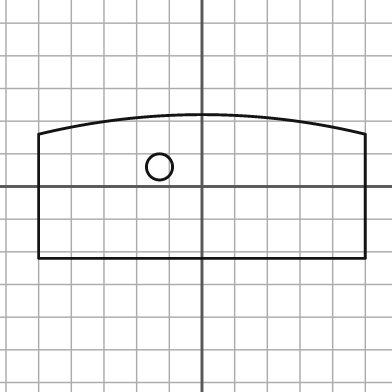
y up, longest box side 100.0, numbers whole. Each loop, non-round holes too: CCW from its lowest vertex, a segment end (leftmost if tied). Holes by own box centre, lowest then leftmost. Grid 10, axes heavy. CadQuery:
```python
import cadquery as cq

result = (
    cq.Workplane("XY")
    .moveTo(-50.0, -22.0)
    .lineTo(50.0, -22.0)
    .lineTo(50.0, 16.0)
    .threePointArc((0.0, 22.0), (-50.0, 16.0))
    .close()
    .moveTo(-13.0, 6.0)
    .circle(4.0)
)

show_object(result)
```